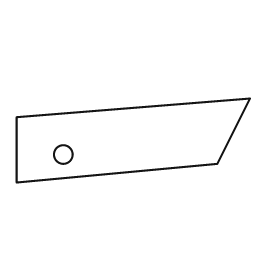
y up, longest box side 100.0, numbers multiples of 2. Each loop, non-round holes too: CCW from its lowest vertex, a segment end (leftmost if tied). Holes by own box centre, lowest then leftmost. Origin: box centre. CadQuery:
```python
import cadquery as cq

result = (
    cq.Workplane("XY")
    .moveTo(-50.0, -18.0)
    .lineTo(36.0, -10.0)
    .lineTo(50.0, 18.0)
    .lineTo(-50.0, 10.0)
    .close()
    .moveTo(-30.0, -6.0)
    .circle(4.0)
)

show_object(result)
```